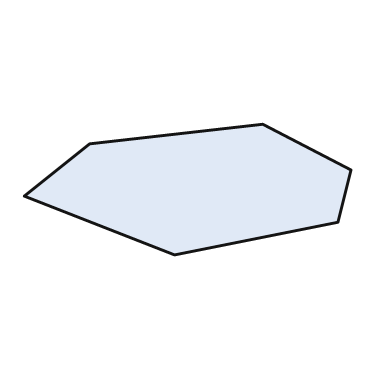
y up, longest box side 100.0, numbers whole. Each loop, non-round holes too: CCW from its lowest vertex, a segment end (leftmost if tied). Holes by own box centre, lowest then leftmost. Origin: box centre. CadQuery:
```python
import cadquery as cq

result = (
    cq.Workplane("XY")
    .moveTo(-4.0, -20.0)
    .lineTo(46.0, -10.0)
    .lineTo(50.0, 6.0)
    .lineTo(23.0, 20.0)
    .lineTo(-30.0, 14.0)
    .lineTo(-50.0, -2.0)
    .close()
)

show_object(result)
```